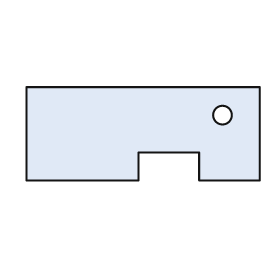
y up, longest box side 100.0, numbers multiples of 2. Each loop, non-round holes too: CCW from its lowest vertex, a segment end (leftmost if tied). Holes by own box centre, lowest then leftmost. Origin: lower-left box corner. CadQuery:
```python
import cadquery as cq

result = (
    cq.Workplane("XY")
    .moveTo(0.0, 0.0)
    .lineTo(48.0, 0.0)
    .lineTo(48.0, 12.0)
    .lineTo(74.0, 12.0)
    .lineTo(74.0, 0.0)
    .lineTo(100.0, 0.0)
    .lineTo(100.0, 40.0)
    .lineTo(0.0, 40.0)
    .close()
    .moveTo(84.0, 28.0)
    .circle(4.0)
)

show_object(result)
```